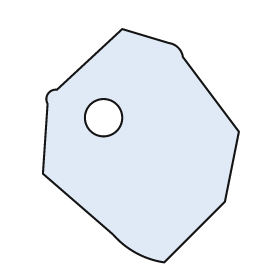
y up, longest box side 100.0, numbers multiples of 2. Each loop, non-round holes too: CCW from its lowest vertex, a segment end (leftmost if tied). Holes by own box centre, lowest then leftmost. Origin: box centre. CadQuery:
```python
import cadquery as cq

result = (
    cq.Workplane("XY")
    .moveTo(10.0, -50.0)
    .lineTo(36.0, -24.0)
    .lineTo(42.0, 6.0)
    .lineTo(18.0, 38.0)
    .threePointArc((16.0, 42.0), (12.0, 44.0))
    .lineTo(-8.0, 50.0)
    .lineTo(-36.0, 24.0)
    .threePointArc((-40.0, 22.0), (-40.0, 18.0))
    .lineTo(-42.0, -12.0)
    .lineTo(-12.0, -38.0)
    .threePointArc((-2.0, -46.0), (10.0, -50.0))
    .close()
    .moveTo(-16.0, 12.0)
    .circle(8.0)
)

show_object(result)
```